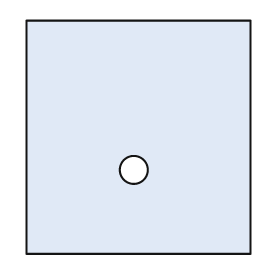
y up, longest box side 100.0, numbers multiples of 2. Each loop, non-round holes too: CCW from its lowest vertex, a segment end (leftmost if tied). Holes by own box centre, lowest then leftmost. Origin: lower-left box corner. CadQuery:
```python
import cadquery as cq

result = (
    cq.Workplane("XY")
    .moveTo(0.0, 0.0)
    .lineTo(96.0, 0.0)
    .lineTo(96.0, 100.0)
    .lineTo(0.0, 100.0)
    .close()
    .moveTo(46.0, 36.0)
    .circle(6.0)
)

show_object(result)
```